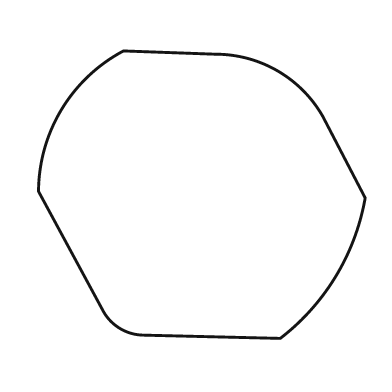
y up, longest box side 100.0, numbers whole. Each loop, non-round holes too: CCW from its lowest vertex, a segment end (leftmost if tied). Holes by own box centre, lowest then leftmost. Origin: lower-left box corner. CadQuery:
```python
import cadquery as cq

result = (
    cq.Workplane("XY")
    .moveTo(74.0, 0.0)
    .threePointArc((91.0, 19.0), (100.0, 43.0))
    .lineTo(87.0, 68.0)
    .threePointArc((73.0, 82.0), (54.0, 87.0))
    .lineTo(26.0, 88.0)
    .threePointArc((7.0, 70.0), (0.0, 45.0))
    .lineTo(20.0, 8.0)
    .threePointArc((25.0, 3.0), (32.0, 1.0))
    .close()
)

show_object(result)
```